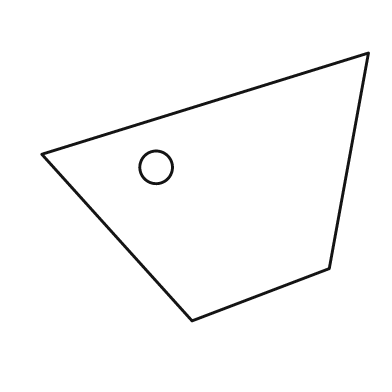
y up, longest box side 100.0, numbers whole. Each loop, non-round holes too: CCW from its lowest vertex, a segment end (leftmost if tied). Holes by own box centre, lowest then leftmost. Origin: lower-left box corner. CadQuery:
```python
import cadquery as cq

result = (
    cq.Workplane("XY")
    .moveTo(46.0, 0.0)
    .lineTo(88.0, 16.0)
    .lineTo(100.0, 82.0)
    .lineTo(0.0, 51.0)
    .close()
    .moveTo(35.0, 47.0)
    .circle(5.0)
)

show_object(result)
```